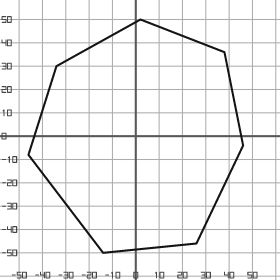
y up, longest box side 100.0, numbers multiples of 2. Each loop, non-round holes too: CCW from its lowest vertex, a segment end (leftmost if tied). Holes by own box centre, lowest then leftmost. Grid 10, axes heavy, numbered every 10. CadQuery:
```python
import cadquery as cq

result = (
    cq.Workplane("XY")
    .moveTo(-14.0, -50.0)
    .lineTo(26.0, -46.0)
    .lineTo(46.0, -4.0)
    .lineTo(38.0, 36.0)
    .lineTo(2.0, 50.0)
    .lineTo(-34.0, 30.0)
    .lineTo(-46.0, -8.0)
    .close()
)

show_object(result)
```